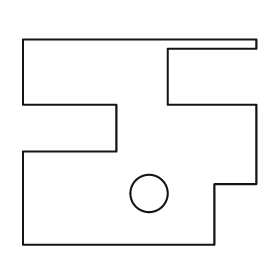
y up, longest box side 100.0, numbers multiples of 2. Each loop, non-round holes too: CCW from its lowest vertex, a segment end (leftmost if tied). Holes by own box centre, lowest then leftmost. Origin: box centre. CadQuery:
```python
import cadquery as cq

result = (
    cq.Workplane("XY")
    .moveTo(-50.0, -44.0)
    .lineTo(32.0, -44.0)
    .lineTo(32.0, -18.0)
    .lineTo(50.0, -18.0)
    .lineTo(50.0, 16.0)
    .lineTo(12.0, 16.0)
    .lineTo(12.0, 40.0)
    .lineTo(50.0, 40.0)
    .lineTo(50.0, 44.0)
    .lineTo(-50.0, 44.0)
    .lineTo(-50.0, 16.0)
    .lineTo(-10.0, 16.0)
    .lineTo(-10.0, -4.0)
    .lineTo(-50.0, -4.0)
    .close()
    .moveTo(4.0, -22.0)
    .circle(8.0)
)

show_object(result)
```